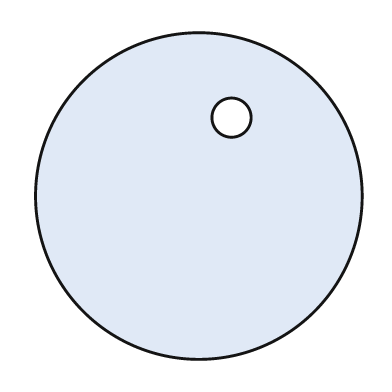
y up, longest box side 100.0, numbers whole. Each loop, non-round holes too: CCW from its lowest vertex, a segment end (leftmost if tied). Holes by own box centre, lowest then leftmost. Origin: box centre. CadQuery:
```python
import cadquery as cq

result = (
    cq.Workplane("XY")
    .moveTo(0.0, 0.0)
    .circle(50.0)
    .moveTo(10.0, 24.0)
    .circle(6.0)
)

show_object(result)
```